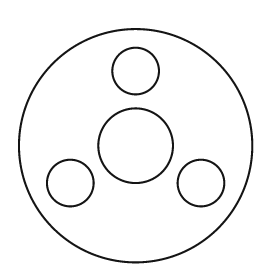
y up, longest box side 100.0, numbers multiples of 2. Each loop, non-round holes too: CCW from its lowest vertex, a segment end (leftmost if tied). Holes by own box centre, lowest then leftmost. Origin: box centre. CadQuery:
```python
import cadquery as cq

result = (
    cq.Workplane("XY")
    .moveTo(0.0, 0.0)
    .circle(50.0)
    .moveTo(-28.0, -16.0)
    .circle(10.0)
    .moveTo(28.0, -16.0)
    .circle(10.0)
    .moveTo(0.0, 0.0)
    .circle(16.0)
    .moveTo(0.0, 32.0)
    .circle(10.0)
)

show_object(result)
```